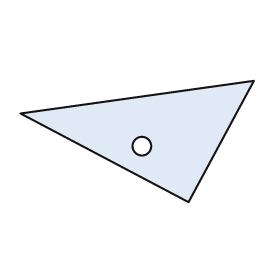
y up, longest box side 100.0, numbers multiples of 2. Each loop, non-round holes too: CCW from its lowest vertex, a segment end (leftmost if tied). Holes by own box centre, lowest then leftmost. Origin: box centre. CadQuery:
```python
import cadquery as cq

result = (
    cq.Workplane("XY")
    .moveTo(22.0, -26.0)
    .lineTo(50.0, 26.0)
    .lineTo(-50.0, 12.0)
    .close()
    .moveTo(2.0, -2.0)
    .circle(4.0)
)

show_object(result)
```